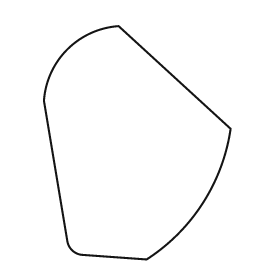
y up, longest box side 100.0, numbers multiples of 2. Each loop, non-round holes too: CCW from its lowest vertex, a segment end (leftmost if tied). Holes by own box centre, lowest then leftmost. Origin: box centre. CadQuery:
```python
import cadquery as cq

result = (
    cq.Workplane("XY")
    .moveTo(4.0, -50.0)
    .threePointArc((28.0, -26.0), (40.0, 6.0))
    .lineTo(-8.0, 50.0)
    .threePointArc((-30.0, 40.0), (-40.0, 18.0))
    .lineTo(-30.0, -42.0)
    .threePointArc((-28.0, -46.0), (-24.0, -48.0))
    .close()
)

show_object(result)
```